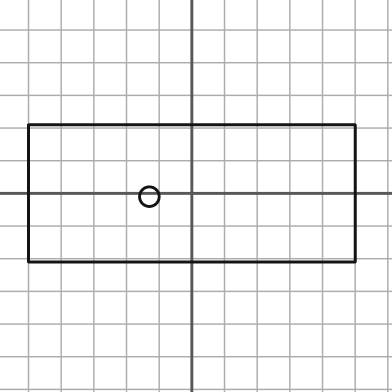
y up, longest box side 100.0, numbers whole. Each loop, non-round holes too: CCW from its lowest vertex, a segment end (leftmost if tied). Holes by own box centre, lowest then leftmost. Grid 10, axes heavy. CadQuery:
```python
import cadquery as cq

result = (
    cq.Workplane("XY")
    .moveTo(-50.0, -21.0)
    .lineTo(50.0, -21.0)
    .lineTo(50.0, 21.0)
    .lineTo(-50.0, 21.0)
    .close()
    .moveTo(-13.0, -1.0)
    .circle(3.0)
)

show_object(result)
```